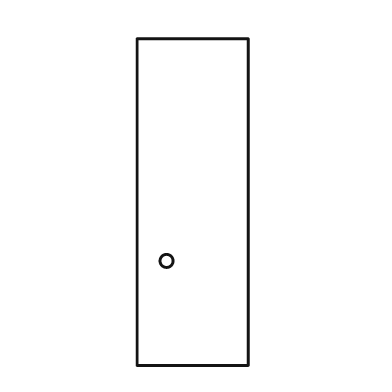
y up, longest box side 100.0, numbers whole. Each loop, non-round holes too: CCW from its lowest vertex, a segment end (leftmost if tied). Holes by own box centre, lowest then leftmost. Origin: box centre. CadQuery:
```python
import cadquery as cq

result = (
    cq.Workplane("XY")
    .moveTo(-17.0, -50.0)
    .lineTo(17.0, -50.0)
    .lineTo(17.0, 50.0)
    .lineTo(-17.0, 50.0)
    .close()
    .moveTo(-8.0, -18.0)
    .circle(2.0)
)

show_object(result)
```